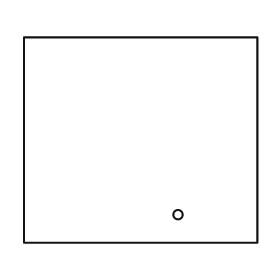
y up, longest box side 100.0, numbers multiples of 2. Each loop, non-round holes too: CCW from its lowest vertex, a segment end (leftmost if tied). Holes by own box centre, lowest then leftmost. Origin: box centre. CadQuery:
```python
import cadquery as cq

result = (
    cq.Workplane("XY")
    .moveTo(-50.0, -44.0)
    .lineTo(50.0, -44.0)
    .lineTo(50.0, 44.0)
    .lineTo(-50.0, 44.0)
    .close()
    .moveTo(16.0, -32.0)
    .circle(2.0)
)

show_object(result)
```